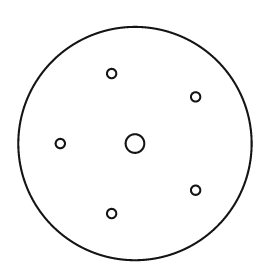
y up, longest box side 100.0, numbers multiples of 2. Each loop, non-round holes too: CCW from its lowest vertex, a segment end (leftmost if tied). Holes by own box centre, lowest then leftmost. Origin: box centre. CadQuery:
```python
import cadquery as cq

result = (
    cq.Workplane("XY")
    .moveTo(0.0, 0.0)
    .circle(50.0)
    .moveTo(-10.0, -30.0)
    .circle(2.0)
    .moveTo(26.0, -20.0)
    .circle(2.0)
    .moveTo(-32.0, 0.0)
    .circle(2.0)
    .moveTo(0.0, 0.0)
    .circle(4.0)
    .moveTo(26.0, 20.0)
    .circle(2.0)
    .moveTo(-10.0, 30.0)
    .circle(2.0)
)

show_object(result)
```